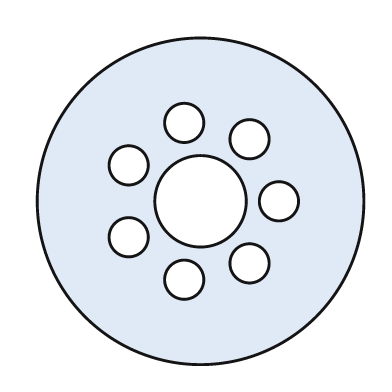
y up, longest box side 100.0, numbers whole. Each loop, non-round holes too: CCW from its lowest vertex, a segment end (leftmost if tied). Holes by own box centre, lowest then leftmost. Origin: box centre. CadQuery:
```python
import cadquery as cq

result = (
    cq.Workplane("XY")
    .moveTo(0.0, 0.0)
    .circle(50.0)
    .moveTo(-5.0, -24.0)
    .circle(6.0)
    .moveTo(15.0, -19.0)
    .circle(6.0)
    .moveTo(-22.0, -11.0)
    .circle(6.0)
    .moveTo(0.0, 0.0)
    .circle(14.0)
    .moveTo(24.0, 0.0)
    .circle(6.0)
    .moveTo(-22.0, 11.0)
    .circle(6.0)
    .moveTo(15.0, 19.0)
    .circle(6.0)
    .moveTo(-5.0, 24.0)
    .circle(6.0)
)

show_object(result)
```